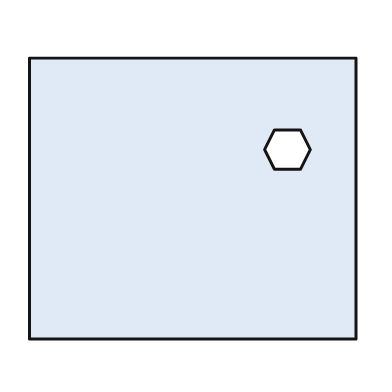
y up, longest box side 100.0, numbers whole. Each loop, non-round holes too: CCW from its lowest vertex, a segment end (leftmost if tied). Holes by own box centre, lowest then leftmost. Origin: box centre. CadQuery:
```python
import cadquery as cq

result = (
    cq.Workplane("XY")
    .moveTo(-50.0, -43.0)
    .lineTo(50.0, -43.0)
    .lineTo(50.0, 43.0)
    .lineTo(-50.0, 43.0)
    .close()
    .moveTo(25.0, 9.0)
    .lineTo(33.0, 9.0)
    .lineTo(36.0, 15.0)
    .lineTo(33.0, 21.0)
    .lineTo(25.0, 21.0)
    .lineTo(22.0, 15.0)
    .close()
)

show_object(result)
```